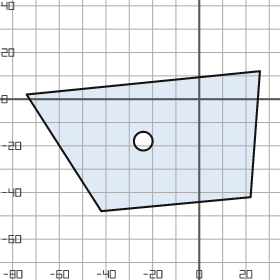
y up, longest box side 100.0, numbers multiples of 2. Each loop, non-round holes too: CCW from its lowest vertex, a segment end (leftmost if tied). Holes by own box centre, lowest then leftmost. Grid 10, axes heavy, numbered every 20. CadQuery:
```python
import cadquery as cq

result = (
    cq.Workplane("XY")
    .moveTo(-42.0, -48.0)
    .lineTo(22.0, -42.0)
    .lineTo(26.0, 12.0)
    .lineTo(-74.0, 2.0)
    .close()
    .moveTo(-24.0, -18.0)
    .circle(4.0)
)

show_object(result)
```